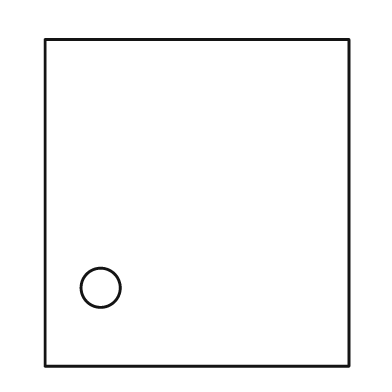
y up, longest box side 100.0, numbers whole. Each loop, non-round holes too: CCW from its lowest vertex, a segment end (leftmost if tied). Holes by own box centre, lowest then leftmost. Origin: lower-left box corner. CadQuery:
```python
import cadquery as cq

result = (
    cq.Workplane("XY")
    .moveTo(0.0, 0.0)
    .lineTo(93.0, 0.0)
    .lineTo(93.0, 100.0)
    .lineTo(0.0, 100.0)
    .close()
    .moveTo(17.0, 24.0)
    .circle(6.0)
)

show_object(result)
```